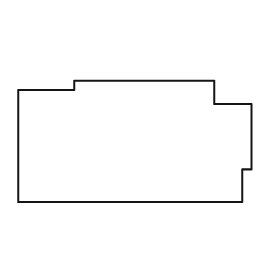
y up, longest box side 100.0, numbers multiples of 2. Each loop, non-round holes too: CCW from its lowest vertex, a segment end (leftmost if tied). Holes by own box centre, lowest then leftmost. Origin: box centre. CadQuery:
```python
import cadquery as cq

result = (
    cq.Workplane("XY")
    .moveTo(-50.0, -26.0)
    .lineTo(46.0, -26.0)
    .lineTo(46.0, -12.0)
    .lineTo(50.0, -12.0)
    .lineTo(50.0, 16.0)
    .lineTo(34.0, 16.0)
    .lineTo(34.0, 26.0)
    .lineTo(-26.0, 26.0)
    .lineTo(-26.0, 22.0)
    .lineTo(-50.0, 22.0)
    .close()
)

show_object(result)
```